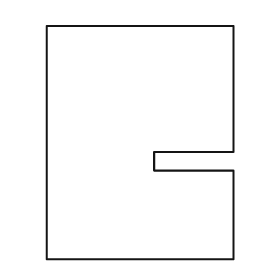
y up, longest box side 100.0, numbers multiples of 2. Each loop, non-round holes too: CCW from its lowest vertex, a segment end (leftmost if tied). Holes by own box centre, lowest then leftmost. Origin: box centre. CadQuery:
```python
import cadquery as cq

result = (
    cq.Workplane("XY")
    .moveTo(-40.0, -50.0)
    .lineTo(40.0, -50.0)
    .lineTo(40.0, -12.0)
    .lineTo(6.0, -12.0)
    .lineTo(6.0, -4.0)
    .lineTo(40.0, -4.0)
    .lineTo(40.0, 50.0)
    .lineTo(-40.0, 50.0)
    .close()
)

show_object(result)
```